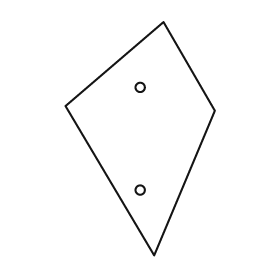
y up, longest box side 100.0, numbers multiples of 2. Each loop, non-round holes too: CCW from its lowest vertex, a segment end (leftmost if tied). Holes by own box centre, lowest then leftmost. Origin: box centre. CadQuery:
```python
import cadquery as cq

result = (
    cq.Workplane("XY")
    .moveTo(6.0, -50.0)
    .lineTo(32.0, 12.0)
    .lineTo(10.0, 50.0)
    .lineTo(-32.0, 14.0)
    .close()
    .moveTo(0.0, -22.0)
    .circle(2.0)
    .moveTo(0.0, 22.0)
    .circle(2.0)
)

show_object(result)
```